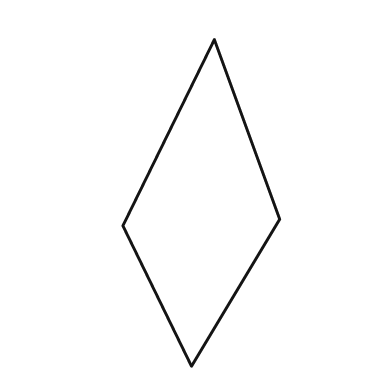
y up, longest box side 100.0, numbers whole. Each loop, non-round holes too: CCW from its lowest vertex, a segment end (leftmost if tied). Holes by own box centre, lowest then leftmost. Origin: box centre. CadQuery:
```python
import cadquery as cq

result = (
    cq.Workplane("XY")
    .moveTo(-3.0, -50.0)
    .lineTo(24.0, -5.0)
    .lineTo(4.0, 50.0)
    .lineTo(-24.0, -7.0)
    .close()
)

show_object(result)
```